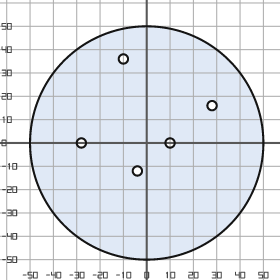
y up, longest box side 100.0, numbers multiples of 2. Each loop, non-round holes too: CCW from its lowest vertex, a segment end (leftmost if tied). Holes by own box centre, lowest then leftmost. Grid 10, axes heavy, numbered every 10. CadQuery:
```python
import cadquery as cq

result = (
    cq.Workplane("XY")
    .moveTo(0.0, 0.0)
    .circle(50.0)
    .moveTo(-4.0, -12.0)
    .circle(2.0)
    .moveTo(-28.0, 0.0)
    .circle(2.0)
    .moveTo(10.0, 0.0)
    .circle(2.0)
    .moveTo(28.0, 16.0)
    .circle(2.0)
    .moveTo(-10.0, 36.0)
    .circle(2.0)
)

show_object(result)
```